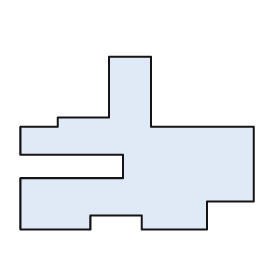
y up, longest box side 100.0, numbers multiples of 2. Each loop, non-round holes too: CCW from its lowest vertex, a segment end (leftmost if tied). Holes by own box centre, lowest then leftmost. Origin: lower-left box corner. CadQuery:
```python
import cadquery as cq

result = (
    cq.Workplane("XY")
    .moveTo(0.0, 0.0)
    .lineTo(30.0, 0.0)
    .lineTo(30.0, 6.0)
    .lineTo(52.0, 6.0)
    .lineTo(52.0, 0.0)
    .lineTo(80.0, 0.0)
    .lineTo(80.0, 12.0)
    .lineTo(100.0, 12.0)
    .lineTo(100.0, 44.0)
    .lineTo(56.0, 44.0)
    .lineTo(56.0, 74.0)
    .lineTo(38.0, 74.0)
    .lineTo(38.0, 48.0)
    .lineTo(16.0, 48.0)
    .lineTo(16.0, 44.0)
    .lineTo(0.0, 44.0)
    .lineTo(0.0, 32.0)
    .lineTo(44.0, 32.0)
    .lineTo(44.0, 22.0)
    .lineTo(0.0, 22.0)
    .close()
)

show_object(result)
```